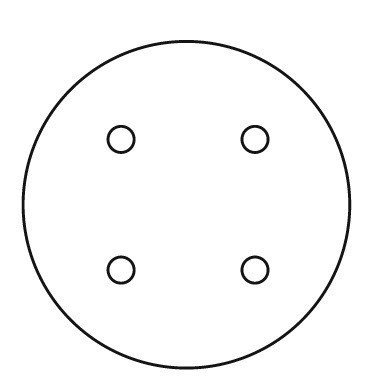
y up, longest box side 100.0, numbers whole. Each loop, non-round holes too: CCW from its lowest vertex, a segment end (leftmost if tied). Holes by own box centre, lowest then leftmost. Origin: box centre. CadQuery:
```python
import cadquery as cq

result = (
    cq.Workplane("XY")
    .moveTo(0.0, 0.0)
    .circle(50.0)
    .moveTo(-20.0, -20.0)
    .circle(4.0)
    .moveTo(21.0, -20.0)
    .circle(4.0)
    .moveTo(-20.0, 20.0)
    .circle(4.0)
    .moveTo(21.0, 20.0)
    .circle(4.0)
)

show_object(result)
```